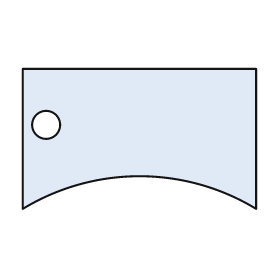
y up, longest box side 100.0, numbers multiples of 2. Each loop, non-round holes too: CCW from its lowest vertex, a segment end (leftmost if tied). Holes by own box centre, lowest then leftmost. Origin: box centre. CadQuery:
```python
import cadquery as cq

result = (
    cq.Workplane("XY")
    .moveTo(-50.0, -30.0)
    .threePointArc((0.0, -16.0), (50.0, -30.0))
    .lineTo(50.0, 30.0)
    .lineTo(-50.0, 30.0)
    .close()
    .moveTo(-40.0, 6.0)
    .circle(6.0)
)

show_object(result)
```